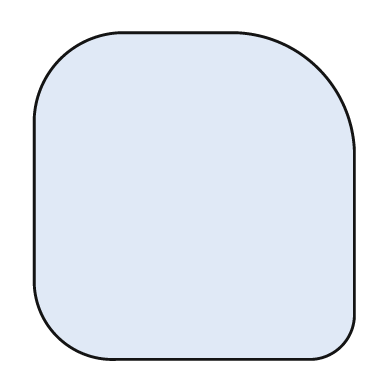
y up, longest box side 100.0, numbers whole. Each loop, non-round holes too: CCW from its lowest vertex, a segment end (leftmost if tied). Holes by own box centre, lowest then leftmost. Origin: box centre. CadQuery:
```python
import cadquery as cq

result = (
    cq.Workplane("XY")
    .moveTo(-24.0, -50.0)
    .lineTo(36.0, -50.0)
    .threePointArc((45.0, -46.0), (49.0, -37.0))
    .lineTo(49.0, 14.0)
    .threePointArc((38.0, 39.0), (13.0, 50.0))
    .lineTo(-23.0, 50.0)
    .threePointArc((-41.0, 42.0), (-49.0, 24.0))
    .lineTo(-49.0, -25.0)
    .threePointArc((-42.0, -43.0), (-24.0, -50.0))
    .close()
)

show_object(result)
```